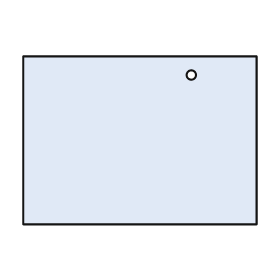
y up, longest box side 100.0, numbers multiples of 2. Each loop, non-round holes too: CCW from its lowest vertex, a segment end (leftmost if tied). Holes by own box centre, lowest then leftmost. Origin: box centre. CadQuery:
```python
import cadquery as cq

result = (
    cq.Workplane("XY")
    .moveTo(-50.0, -36.0)
    .lineTo(50.0, -36.0)
    .lineTo(50.0, 36.0)
    .lineTo(-50.0, 36.0)
    .close()
    .moveTo(22.0, 28.0)
    .circle(2.0)
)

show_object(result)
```